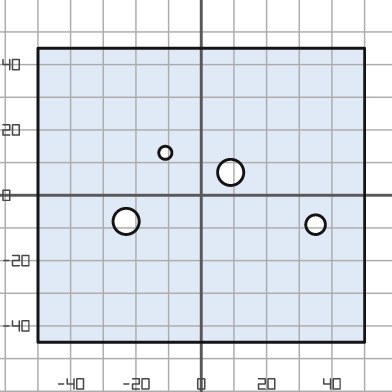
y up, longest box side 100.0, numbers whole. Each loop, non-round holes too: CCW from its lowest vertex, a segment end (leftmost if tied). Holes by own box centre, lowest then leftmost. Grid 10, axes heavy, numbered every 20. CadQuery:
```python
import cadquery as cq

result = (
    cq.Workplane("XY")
    .moveTo(-50.0, -45.0)
    .lineTo(50.0, -45.0)
    .lineTo(50.0, 45.0)
    .lineTo(-50.0, 45.0)
    .close()
    .moveTo(35.0, -9.0)
    .circle(3.0)
    .moveTo(-23.0, -8.0)
    .circle(4.0)
    .moveTo(9.0, 7.0)
    .circle(4.0)
    .moveTo(-11.0, 13.0)
    .circle(2.0)
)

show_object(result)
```